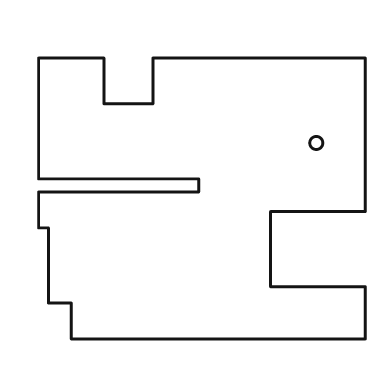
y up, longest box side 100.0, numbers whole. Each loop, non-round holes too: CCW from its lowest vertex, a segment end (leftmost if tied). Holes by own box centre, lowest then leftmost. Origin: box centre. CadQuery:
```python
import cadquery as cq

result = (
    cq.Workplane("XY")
    .moveTo(-40.0, -43.0)
    .lineTo(50.0, -43.0)
    .lineTo(50.0, -27.0)
    .lineTo(21.0, -27.0)
    .lineTo(21.0, -4.0)
    .lineTo(50.0, -4.0)
    .lineTo(50.0, 43.0)
    .lineTo(-15.0, 43.0)
    .lineTo(-15.0, 29.0)
    .lineTo(-30.0, 29.0)
    .lineTo(-30.0, 43.0)
    .lineTo(-50.0, 43.0)
    .lineTo(-50.0, 6.0)
    .lineTo(-1.0, 6.0)
    .lineTo(-1.0, 2.0)
    .lineTo(-50.0, 2.0)
    .lineTo(-50.0, -9.0)
    .lineTo(-47.0, -9.0)
    .lineTo(-47.0, -32.0)
    .lineTo(-40.0, -32.0)
    .close()
    .moveTo(35.0, 17.0)
    .circle(2.0)
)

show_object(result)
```